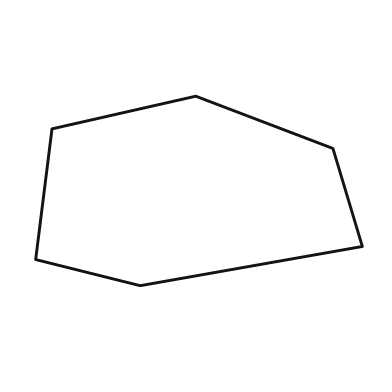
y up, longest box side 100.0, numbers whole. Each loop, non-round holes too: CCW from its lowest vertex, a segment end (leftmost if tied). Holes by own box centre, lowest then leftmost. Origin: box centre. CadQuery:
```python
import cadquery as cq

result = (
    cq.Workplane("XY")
    .moveTo(-18.0, -29.0)
    .lineTo(50.0, -17.0)
    .lineTo(41.0, 13.0)
    .lineTo(-1.0, 29.0)
    .lineTo(-45.0, 19.0)
    .lineTo(-50.0, -21.0)
    .close()
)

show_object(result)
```